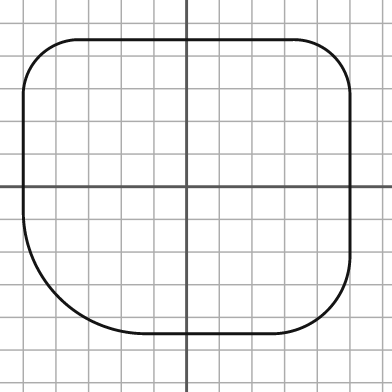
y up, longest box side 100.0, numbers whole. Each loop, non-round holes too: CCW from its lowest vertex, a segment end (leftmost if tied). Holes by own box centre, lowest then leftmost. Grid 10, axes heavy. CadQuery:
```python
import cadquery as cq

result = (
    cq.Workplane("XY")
    .moveTo(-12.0, -45.0)
    .lineTo(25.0, -45.0)
    .threePointArc((43.0, -38.0), (50.0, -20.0))
    .lineTo(50.0, 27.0)
    .threePointArc((45.0, 40.0), (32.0, 45.0))
    .lineTo(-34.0, 45.0)
    .threePointArc((-45.0, 40.0), (-50.0, 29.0))
    .lineTo(-50.0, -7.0)
    .threePointArc((-39.0, -34.0), (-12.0, -45.0))
    .close()
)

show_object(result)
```